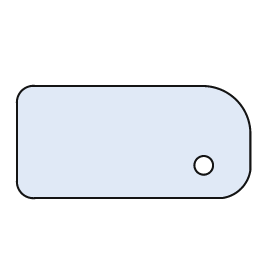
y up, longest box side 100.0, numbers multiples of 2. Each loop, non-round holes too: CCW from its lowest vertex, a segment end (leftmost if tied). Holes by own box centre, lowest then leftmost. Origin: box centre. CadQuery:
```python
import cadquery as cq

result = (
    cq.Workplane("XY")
    .moveTo(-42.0, -24.0)
    .lineTo(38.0, -24.0)
    .threePointArc((46.0, -20.0), (50.0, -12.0))
    .lineTo(50.0, 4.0)
    .threePointArc((44.0, 18.0), (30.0, 24.0))
    .lineTo(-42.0, 24.0)
    .threePointArc((-48.0, 22.0), (-50.0, 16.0))
    .lineTo(-50.0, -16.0)
    .threePointArc((-48.0, -22.0), (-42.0, -24.0))
    .close()
    .moveTo(30.0, -10.0)
    .circle(4.0)
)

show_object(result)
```